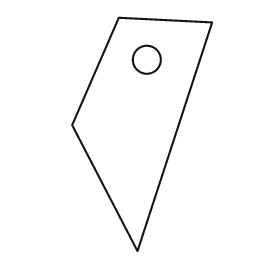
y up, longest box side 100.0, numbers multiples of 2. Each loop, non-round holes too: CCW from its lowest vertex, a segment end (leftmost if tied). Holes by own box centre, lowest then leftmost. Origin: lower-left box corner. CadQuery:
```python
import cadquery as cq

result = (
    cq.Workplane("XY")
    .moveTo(28.0, 0.0)
    .lineTo(60.0, 98.0)
    .lineTo(20.0, 100.0)
    .lineTo(0.0, 54.0)
    .close()
    .moveTo(32.0, 82.0)
    .circle(6.0)
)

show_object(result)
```